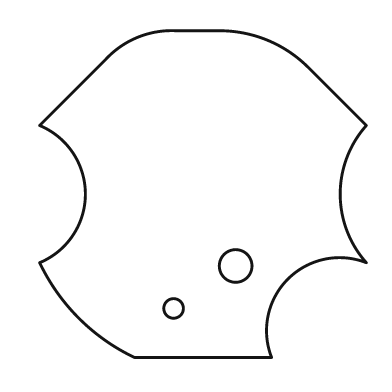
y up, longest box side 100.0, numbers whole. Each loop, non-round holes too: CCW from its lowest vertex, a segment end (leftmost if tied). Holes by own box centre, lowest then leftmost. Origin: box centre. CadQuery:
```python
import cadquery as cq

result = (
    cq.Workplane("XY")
    .moveTo(-21.0, -50.0)
    .lineTo(21.0, -50.0)
    .threePointArc((26.0, -26.0), (50.0, -21.0))
    .threePointArc((42.0, 0.0), (50.0, 21.0))
    .lineTo(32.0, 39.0)
    .threePointArc((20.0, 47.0), (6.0, 50.0))
    .lineTo(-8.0, 50.0)
    .threePointArc((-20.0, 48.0), (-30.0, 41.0))
    .lineTo(-50.0, 21.0)
    .threePointArc((-36.0, 0.0), (-50.0, -21.0))
    .threePointArc((-38.0, -38.0), (-21.0, -50.0))
    .close()
    .moveTo(-9.0, -35.0)
    .circle(3.0)
    .moveTo(10.0, -22.0)
    .circle(5.0)
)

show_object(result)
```